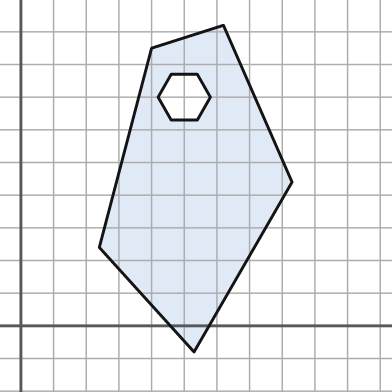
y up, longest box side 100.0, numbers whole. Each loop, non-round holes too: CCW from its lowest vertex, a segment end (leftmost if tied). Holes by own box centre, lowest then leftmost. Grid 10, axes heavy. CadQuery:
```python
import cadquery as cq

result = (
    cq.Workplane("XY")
    .moveTo(53.0, -8.0)
    .lineTo(83.0, 44.0)
    .lineTo(62.0, 92.0)
    .lineTo(40.0, 85.0)
    .lineTo(24.0, 24.0)
    .close()
    .moveTo(46.0, 63.0)
    .lineTo(54.0, 63.0)
    .lineTo(58.0, 70.0)
    .lineTo(54.0, 77.0)
    .lineTo(46.0, 77.0)
    .lineTo(42.0, 70.0)
    .close()
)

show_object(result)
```